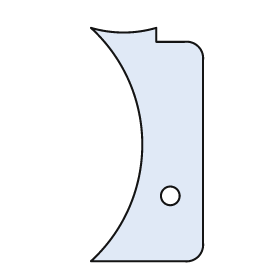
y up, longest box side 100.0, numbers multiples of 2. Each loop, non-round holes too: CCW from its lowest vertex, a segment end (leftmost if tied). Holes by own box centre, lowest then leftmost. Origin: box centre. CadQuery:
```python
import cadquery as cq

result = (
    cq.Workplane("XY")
    .moveTo(-24.0, -50.0)
    .lineTo(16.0, -50.0)
    .threePointArc((22.0, -48.0), (24.0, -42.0))
    .lineTo(24.0, 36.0)
    .threePointArc((22.0, 42.0), (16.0, 44.0))
    .lineTo(4.0, 44.0)
    .lineTo(4.0, 50.0)
    .threePointArc((-10.0, 48.0), (-24.0, 50.0))
    .threePointArc((-2.0, 0.0), (-24.0, -50.0))
    .close()
    .moveTo(10.0, -22.0)
    .circle(4.0)
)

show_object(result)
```